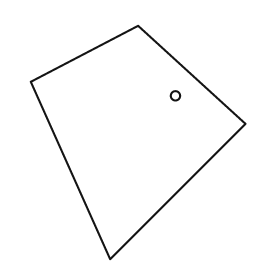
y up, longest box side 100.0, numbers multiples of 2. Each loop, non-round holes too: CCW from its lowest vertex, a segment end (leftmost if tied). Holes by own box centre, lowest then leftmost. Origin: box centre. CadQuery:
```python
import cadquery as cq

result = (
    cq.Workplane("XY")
    .moveTo(-12.0, -50.0)
    .lineTo(46.0, 8.0)
    .lineTo(0.0, 50.0)
    .lineTo(-46.0, 26.0)
    .close()
    .moveTo(16.0, 20.0)
    .circle(2.0)
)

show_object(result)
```